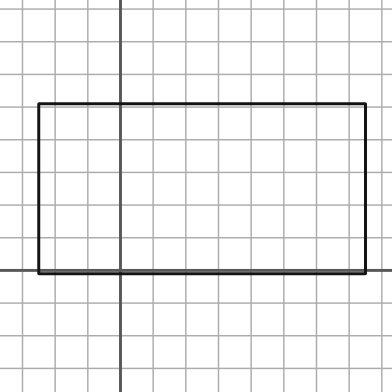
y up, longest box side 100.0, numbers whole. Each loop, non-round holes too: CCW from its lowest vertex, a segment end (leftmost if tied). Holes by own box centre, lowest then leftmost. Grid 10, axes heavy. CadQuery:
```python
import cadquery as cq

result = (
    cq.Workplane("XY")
    .moveTo(-25.0, -1.0)
    .lineTo(75.0, -1.0)
    .lineTo(75.0, 51.0)
    .lineTo(-25.0, 51.0)
    .close()
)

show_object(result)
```